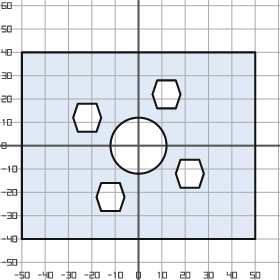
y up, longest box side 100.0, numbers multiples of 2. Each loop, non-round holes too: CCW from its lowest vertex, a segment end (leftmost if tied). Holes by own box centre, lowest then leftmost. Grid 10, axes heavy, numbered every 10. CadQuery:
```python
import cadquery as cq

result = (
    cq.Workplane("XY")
    .moveTo(-50.0, -40.0)
    .lineTo(50.0, -40.0)
    .lineTo(50.0, 40.0)
    .lineTo(-50.0, 40.0)
    .close()
    .moveTo(-16.0, -28.0)
    .lineTo(-8.0, -28.0)
    .lineTo(-6.0, -22.0)
    .lineTo(-8.0, -16.0)
    .lineTo(-16.0, -16.0)
    .lineTo(-18.0, -22.0)
    .close()
    .moveTo(18.0, -18.0)
    .lineTo(26.0, -18.0)
    .lineTo(28.0, -12.0)
    .lineTo(26.0, -6.0)
    .lineTo(18.0, -6.0)
    .lineTo(16.0, -12.0)
    .close()
    .moveTo(0.0, 0.0)
    .circle(12.0)
    .moveTo(-26.0, 6.0)
    .lineTo(-18.0, 6.0)
    .lineTo(-16.0, 12.0)
    .lineTo(-18.0, 18.0)
    .lineTo(-26.0, 18.0)
    .lineTo(-28.0, 12.0)
    .close()
    .moveTo(8.0, 16.0)
    .lineTo(16.0, 16.0)
    .lineTo(18.0, 22.0)
    .lineTo(16.0, 28.0)
    .lineTo(8.0, 28.0)
    .lineTo(6.0, 22.0)
    .close()
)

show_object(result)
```